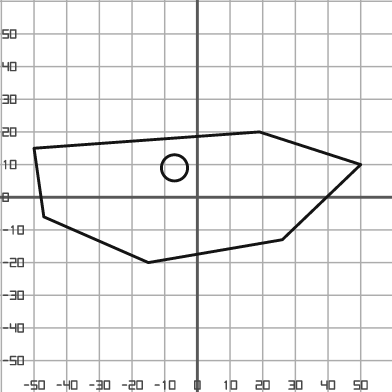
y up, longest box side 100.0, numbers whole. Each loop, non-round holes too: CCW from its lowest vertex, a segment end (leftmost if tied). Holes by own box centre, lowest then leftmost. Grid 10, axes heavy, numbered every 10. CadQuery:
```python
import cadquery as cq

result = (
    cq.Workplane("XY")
    .moveTo(-15.0, -20.0)
    .lineTo(26.0, -13.0)
    .lineTo(50.0, 10.0)
    .lineTo(19.0, 20.0)
    .lineTo(-50.0, 15.0)
    .lineTo(-47.0, -6.0)
    .close()
    .moveTo(-7.0, 9.0)
    .circle(4.0)
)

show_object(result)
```